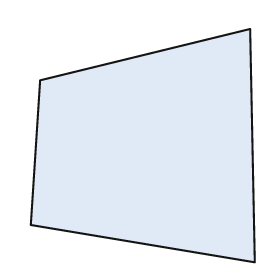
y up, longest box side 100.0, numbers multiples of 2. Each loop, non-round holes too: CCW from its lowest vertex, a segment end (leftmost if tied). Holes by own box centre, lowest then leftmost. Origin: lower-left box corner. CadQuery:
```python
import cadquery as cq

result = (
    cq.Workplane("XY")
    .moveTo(96.0, 0.0)
    .lineTo(94.0, 100.0)
    .lineTo(4.0, 78.0)
    .lineTo(0.0, 16.0)
    .close()
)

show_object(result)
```